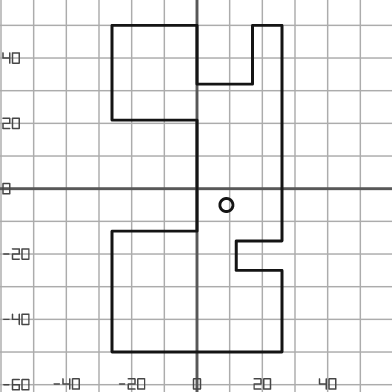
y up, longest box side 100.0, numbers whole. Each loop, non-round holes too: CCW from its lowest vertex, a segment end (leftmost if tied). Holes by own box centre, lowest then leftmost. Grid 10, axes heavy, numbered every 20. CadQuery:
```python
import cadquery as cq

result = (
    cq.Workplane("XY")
    .moveTo(-26.0, -50.0)
    .lineTo(26.0, -50.0)
    .lineTo(26.0, -25.0)
    .lineTo(12.0, -25.0)
    .lineTo(12.0, -16.0)
    .lineTo(26.0, -16.0)
    .lineTo(26.0, 50.0)
    .lineTo(17.0, 50.0)
    .lineTo(17.0, 32.0)
    .lineTo(0.0, 32.0)
    .lineTo(0.0, 50.0)
    .lineTo(-26.0, 50.0)
    .lineTo(-26.0, 21.0)
    .lineTo(0.0, 21.0)
    .lineTo(0.0, -13.0)
    .lineTo(-26.0, -13.0)
    .close()
    .moveTo(9.0, -5.0)
    .circle(2.0)
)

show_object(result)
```